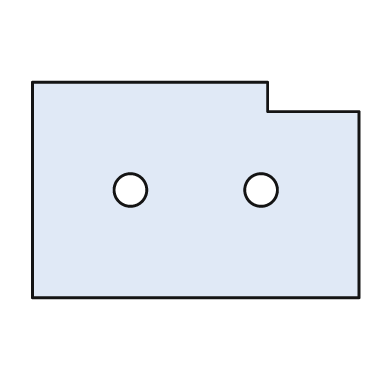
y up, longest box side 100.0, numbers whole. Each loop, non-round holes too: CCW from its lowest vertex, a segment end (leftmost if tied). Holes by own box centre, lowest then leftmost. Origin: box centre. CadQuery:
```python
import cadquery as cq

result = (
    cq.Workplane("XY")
    .moveTo(-50.0, -33.0)
    .lineTo(50.0, -33.0)
    .lineTo(50.0, 24.0)
    .lineTo(22.0, 24.0)
    .lineTo(22.0, 33.0)
    .lineTo(-50.0, 33.0)
    .close()
    .moveTo(-20.0, 0.0)
    .circle(5.0)
    .moveTo(20.0, 0.0)
    .circle(5.0)
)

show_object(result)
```